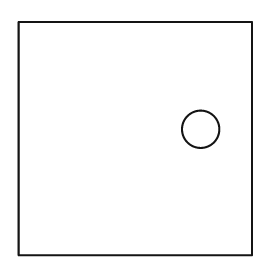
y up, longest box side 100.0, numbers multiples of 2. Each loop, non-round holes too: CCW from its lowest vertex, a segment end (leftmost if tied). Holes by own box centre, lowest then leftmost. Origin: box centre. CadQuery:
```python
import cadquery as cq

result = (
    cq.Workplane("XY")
    .moveTo(-50.0, -50.0)
    .lineTo(50.0, -50.0)
    .lineTo(50.0, 50.0)
    .lineTo(-50.0, 50.0)
    .close()
    .moveTo(28.0, 4.0)
    .circle(8.0)
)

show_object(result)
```